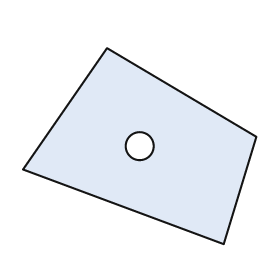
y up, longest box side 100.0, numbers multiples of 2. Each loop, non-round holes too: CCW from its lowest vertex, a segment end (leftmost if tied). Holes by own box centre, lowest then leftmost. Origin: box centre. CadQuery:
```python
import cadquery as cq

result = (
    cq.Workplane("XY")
    .moveTo(36.0, -42.0)
    .lineTo(50.0, 4.0)
    .lineTo(-14.0, 42.0)
    .lineTo(-50.0, -10.0)
    .close()
    .moveTo(0.0, 0.0)
    .circle(6.0)
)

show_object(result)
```